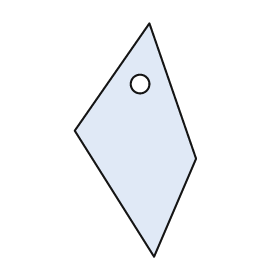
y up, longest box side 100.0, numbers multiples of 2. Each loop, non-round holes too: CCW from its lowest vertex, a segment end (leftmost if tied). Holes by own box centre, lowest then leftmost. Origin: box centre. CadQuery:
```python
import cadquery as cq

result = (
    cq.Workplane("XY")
    .moveTo(8.0, -50.0)
    .lineTo(26.0, -8.0)
    .lineTo(6.0, 50.0)
    .lineTo(-26.0, 4.0)
    .close()
    .moveTo(2.0, 24.0)
    .circle(4.0)
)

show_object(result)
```